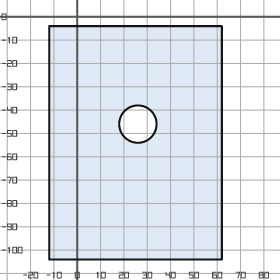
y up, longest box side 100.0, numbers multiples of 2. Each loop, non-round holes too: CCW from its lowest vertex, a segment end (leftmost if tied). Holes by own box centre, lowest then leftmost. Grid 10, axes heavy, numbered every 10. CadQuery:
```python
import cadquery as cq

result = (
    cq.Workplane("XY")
    .moveTo(-12.0, -104.0)
    .lineTo(62.0, -104.0)
    .lineTo(62.0, -4.0)
    .lineTo(-12.0, -4.0)
    .close()
    .moveTo(26.0, -46.0)
    .circle(8.0)
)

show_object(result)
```